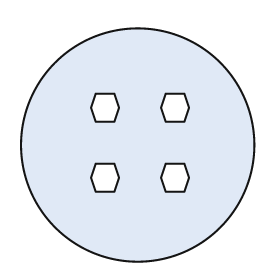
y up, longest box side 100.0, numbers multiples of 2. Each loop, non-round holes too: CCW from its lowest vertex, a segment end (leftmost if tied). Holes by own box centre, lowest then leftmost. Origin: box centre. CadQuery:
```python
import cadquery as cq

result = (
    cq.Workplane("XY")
    .moveTo(0.0, 0.0)
    .circle(50.0)
    .moveTo(-18.0, -20.0)
    .lineTo(-10.0, -20.0)
    .lineTo(-8.0, -14.0)
    .lineTo(-10.0, -8.0)
    .lineTo(-18.0, -8.0)
    .lineTo(-20.0, -14.0)
    .close()
    .moveTo(12.0, -20.0)
    .lineTo(20.0, -20.0)
    .lineTo(22.0, -14.0)
    .lineTo(20.0, -8.0)
    .lineTo(12.0, -8.0)
    .lineTo(10.0, -14.0)
    .close()
    .moveTo(-18.0, 10.0)
    .lineTo(-10.0, 10.0)
    .lineTo(-8.0, 16.0)
    .lineTo(-10.0, 22.0)
    .lineTo(-18.0, 22.0)
    .lineTo(-20.0, 16.0)
    .close()
    .moveTo(12.0, 10.0)
    .lineTo(20.0, 10.0)
    .lineTo(22.0, 16.0)
    .lineTo(20.0, 22.0)
    .lineTo(12.0, 22.0)
    .lineTo(10.0, 16.0)
    .close()
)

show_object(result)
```